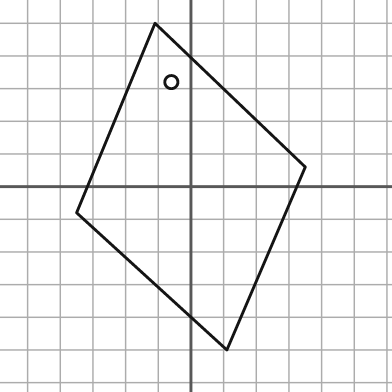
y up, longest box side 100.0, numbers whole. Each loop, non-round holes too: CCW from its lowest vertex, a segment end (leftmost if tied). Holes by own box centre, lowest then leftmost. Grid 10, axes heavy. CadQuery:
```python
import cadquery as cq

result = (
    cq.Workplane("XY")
    .moveTo(11.0, -50.0)
    .lineTo(35.0, 6.0)
    .lineTo(-11.0, 50.0)
    .lineTo(-35.0, -8.0)
    .close()
    .moveTo(-6.0, 32.0)
    .circle(2.0)
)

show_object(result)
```